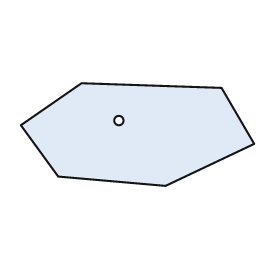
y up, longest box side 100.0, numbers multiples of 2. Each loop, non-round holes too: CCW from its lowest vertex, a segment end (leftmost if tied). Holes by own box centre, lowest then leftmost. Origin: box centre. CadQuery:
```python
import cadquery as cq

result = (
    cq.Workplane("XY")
    .moveTo(12.0, -22.0)
    .lineTo(50.0, -4.0)
    .lineTo(36.0, 20.0)
    .lineTo(-24.0, 22.0)
    .lineTo(-50.0, 4.0)
    .lineTo(-34.0, -18.0)
    .close()
    .moveTo(-8.0, 6.0)
    .circle(2.0)
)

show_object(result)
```